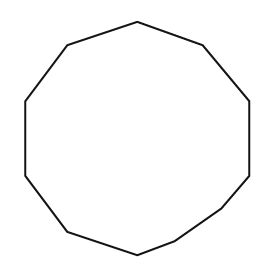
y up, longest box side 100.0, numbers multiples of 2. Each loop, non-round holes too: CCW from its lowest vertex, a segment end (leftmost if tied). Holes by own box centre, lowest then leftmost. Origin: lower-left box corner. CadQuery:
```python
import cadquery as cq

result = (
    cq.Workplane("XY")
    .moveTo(48.0, 0.0)
    .lineTo(64.0, 6.0)
    .lineTo(84.0, 20.0)
    .lineTo(96.0, 34.0)
    .lineTo(96.0, 66.0)
    .lineTo(76.0, 90.0)
    .lineTo(48.0, 100.0)
    .lineTo(18.0, 90.0)
    .lineTo(0.0, 66.0)
    .lineTo(0.0, 34.0)
    .lineTo(18.0, 10.0)
    .close()
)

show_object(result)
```